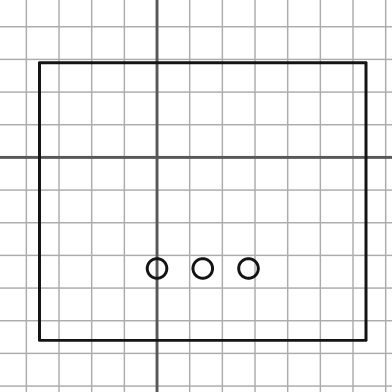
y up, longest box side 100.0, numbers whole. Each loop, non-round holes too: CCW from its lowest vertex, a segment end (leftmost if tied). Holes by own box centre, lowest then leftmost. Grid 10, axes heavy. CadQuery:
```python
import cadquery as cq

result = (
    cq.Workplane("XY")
    .moveTo(-36.0, -56.0)
    .lineTo(64.0, -56.0)
    .lineTo(64.0, 29.0)
    .lineTo(-36.0, 29.0)
    .close()
    .moveTo(0.0, -34.0)
    .circle(3.0)
    .moveTo(14.0, -34.0)
    .circle(3.0)
    .moveTo(28.0, -34.0)
    .circle(3.0)
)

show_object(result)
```